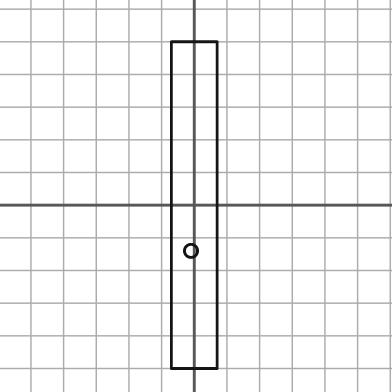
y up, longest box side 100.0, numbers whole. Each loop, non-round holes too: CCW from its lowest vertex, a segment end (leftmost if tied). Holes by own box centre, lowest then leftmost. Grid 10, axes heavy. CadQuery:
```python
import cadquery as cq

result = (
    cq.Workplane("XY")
    .moveTo(-7.0, -50.0)
    .lineTo(7.0, -50.0)
    .lineTo(7.0, 50.0)
    .lineTo(-7.0, 50.0)
    .close()
    .moveTo(-1.0, -14.0)
    .circle(2.0)
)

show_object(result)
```